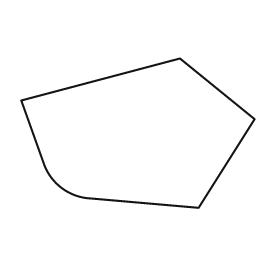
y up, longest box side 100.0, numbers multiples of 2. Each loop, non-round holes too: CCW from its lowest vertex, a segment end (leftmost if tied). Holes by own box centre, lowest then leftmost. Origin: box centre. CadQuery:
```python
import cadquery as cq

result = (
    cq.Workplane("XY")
    .moveTo(26.0, -32.0)
    .lineTo(50.0, 6.0)
    .lineTo(18.0, 32.0)
    .lineTo(-50.0, 14.0)
    .lineTo(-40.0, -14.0)
    .threePointArc((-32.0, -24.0), (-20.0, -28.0))
    .close()
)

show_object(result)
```